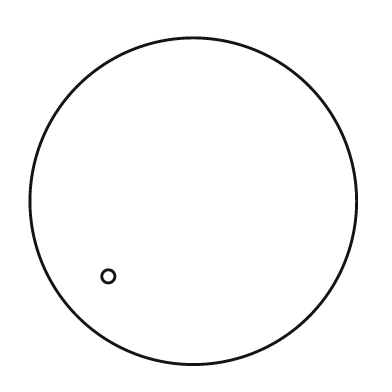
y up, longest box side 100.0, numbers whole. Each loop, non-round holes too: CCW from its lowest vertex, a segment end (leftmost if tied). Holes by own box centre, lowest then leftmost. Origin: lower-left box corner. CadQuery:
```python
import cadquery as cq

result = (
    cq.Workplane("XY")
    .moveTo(50.0, 50.0)
    .circle(50.0)
    .moveTo(24.0, 27.0)
    .circle(2.0)
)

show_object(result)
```